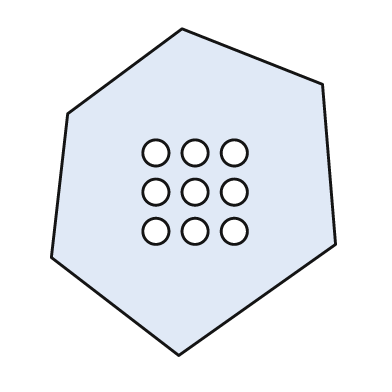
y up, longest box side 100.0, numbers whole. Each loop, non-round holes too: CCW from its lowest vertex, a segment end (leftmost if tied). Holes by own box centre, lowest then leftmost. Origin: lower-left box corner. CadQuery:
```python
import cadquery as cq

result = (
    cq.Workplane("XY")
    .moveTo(39.0, 0.0)
    .lineTo(87.0, 34.0)
    .lineTo(83.0, 83.0)
    .lineTo(40.0, 100.0)
    .lineTo(5.0, 74.0)
    .lineTo(0.0, 30.0)
    .close()
    .moveTo(32.0, 38.0)
    .circle(4.0)
    .moveTo(44.0, 38.0)
    .circle(4.0)
    .moveTo(56.0, 38.0)
    .circle(4.0)
    .moveTo(32.0, 50.0)
    .circle(4.0)
    .moveTo(44.0, 50.0)
    .circle(4.0)
    .moveTo(56.0, 50.0)
    .circle(4.0)
    .moveTo(32.0, 62.0)
    .circle(4.0)
    .moveTo(44.0, 62.0)
    .circle(4.0)
    .moveTo(56.0, 62.0)
    .circle(4.0)
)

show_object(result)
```